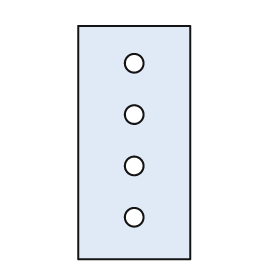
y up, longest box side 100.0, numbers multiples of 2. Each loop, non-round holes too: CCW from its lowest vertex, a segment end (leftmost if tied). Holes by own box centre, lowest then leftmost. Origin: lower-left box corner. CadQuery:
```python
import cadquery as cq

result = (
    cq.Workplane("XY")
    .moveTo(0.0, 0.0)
    .lineTo(48.0, 0.0)
    .lineTo(48.0, 100.0)
    .lineTo(0.0, 100.0)
    .close()
    .moveTo(24.0, 18.0)
    .circle(4.0)
    .moveTo(24.0, 40.0)
    .circle(4.0)
    .moveTo(24.0, 62.0)
    .circle(4.0)
    .moveTo(24.0, 84.0)
    .circle(4.0)
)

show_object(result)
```